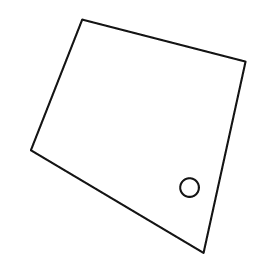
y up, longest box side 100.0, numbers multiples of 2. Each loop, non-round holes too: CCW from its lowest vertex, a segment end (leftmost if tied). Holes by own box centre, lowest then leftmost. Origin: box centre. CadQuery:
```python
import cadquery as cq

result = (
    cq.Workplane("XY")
    .moveTo(28.0, -50.0)
    .lineTo(46.0, 32.0)
    .lineTo(-24.0, 50.0)
    .lineTo(-46.0, -6.0)
    .close()
    .moveTo(22.0, -22.0)
    .circle(4.0)
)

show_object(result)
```